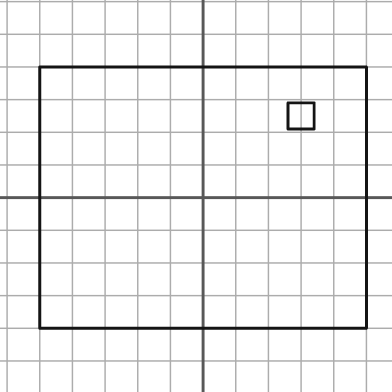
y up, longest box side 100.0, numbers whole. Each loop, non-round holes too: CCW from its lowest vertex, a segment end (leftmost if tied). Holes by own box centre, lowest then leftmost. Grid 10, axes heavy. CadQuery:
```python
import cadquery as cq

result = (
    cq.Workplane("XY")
    .moveTo(-50.0, -40.0)
    .lineTo(50.0, -40.0)
    .lineTo(50.0, 40.0)
    .lineTo(-50.0, 40.0)
    .close()
    .moveTo(26.0, 21.0)
    .lineTo(34.0, 21.0)
    .lineTo(34.0, 29.0)
    .lineTo(26.0, 29.0)
    .close()
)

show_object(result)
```